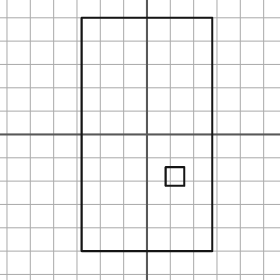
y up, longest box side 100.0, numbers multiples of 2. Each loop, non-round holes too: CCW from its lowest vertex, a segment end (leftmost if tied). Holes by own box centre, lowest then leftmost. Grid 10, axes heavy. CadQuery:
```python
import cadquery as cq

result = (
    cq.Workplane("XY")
    .moveTo(-28.0, -50.0)
    .lineTo(28.0, -50.0)
    .lineTo(28.0, 50.0)
    .lineTo(-28.0, 50.0)
    .close()
    .moveTo(8.0, -22.0)
    .lineTo(16.0, -22.0)
    .lineTo(16.0, -14.0)
    .lineTo(8.0, -14.0)
    .close()
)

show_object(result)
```